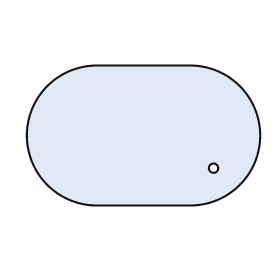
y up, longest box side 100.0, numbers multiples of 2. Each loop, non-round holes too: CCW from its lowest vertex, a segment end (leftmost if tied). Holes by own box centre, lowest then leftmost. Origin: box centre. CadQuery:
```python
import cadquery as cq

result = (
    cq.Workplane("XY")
    .moveTo(-20.0, -30.0)
    .lineTo(20.0, -30.0)
    .threePointArc((50.0, 0.0), (20.0, 30.0))
    .lineTo(-20.0, 30.0)
    .threePointArc((-50.0, 0.0), (-20.0, -30.0))
    .close()
    .moveTo(30.0, -14.0)
    .circle(2.0)
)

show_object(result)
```